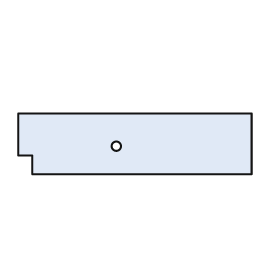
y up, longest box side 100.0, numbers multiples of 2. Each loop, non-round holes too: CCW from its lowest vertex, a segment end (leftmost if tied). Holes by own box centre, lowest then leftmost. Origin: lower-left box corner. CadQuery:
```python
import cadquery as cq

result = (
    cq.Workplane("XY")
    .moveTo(6.0, 0.0)
    .lineTo(100.0, 0.0)
    .lineTo(100.0, 26.0)
    .lineTo(0.0, 26.0)
    .lineTo(0.0, 8.0)
    .lineTo(6.0, 8.0)
    .close()
    .moveTo(42.0, 12.0)
    .circle(2.0)
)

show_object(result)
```